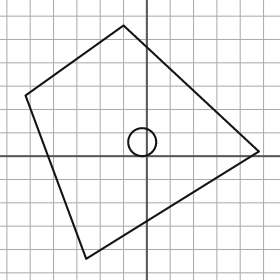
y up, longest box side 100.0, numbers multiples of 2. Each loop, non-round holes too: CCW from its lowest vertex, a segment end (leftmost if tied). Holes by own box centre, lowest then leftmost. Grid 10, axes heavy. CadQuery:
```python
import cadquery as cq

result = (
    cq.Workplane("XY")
    .moveTo(-26.0, -44.0)
    .lineTo(48.0, 2.0)
    .lineTo(-10.0, 56.0)
    .lineTo(-52.0, 26.0)
    .close()
    .moveTo(-2.0, 6.0)
    .circle(6.0)
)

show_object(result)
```